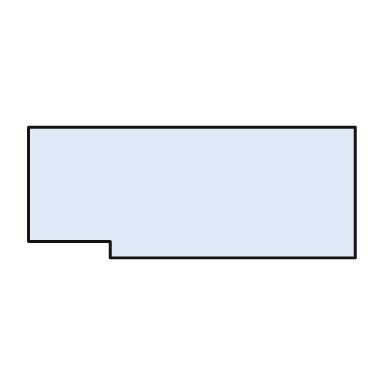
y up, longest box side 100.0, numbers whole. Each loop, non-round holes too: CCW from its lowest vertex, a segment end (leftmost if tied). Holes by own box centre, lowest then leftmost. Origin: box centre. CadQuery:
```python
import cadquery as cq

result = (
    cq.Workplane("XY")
    .moveTo(-25.0, -20.0)
    .lineTo(50.0, -20.0)
    .lineTo(50.0, 20.0)
    .lineTo(-50.0, 20.0)
    .lineTo(-50.0, -15.0)
    .lineTo(-25.0, -15.0)
    .close()
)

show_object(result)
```